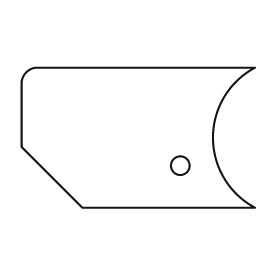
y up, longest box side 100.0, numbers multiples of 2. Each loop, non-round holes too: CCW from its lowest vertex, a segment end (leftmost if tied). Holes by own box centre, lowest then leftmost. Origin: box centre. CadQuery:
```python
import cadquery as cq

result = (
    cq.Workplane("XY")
    .moveTo(-24.0, -30.0)
    .lineTo(50.0, -30.0)
    .threePointArc((32.0, 0.0), (50.0, 30.0))
    .lineTo(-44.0, 30.0)
    .threePointArc((-48.0, 28.0), (-50.0, 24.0))
    .lineTo(-50.0, -4.0)
    .close()
    .moveTo(18.0, -12.0)
    .circle(4.0)
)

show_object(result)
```